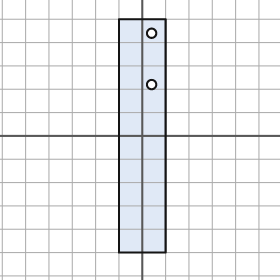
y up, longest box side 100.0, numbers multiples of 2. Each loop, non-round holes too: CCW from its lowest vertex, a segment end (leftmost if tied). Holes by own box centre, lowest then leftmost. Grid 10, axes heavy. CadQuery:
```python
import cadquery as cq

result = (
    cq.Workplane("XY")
    .moveTo(-10.0, -50.0)
    .lineTo(10.0, -50.0)
    .lineTo(10.0, 50.0)
    .lineTo(-10.0, 50.0)
    .close()
    .moveTo(4.0, 22.0)
    .circle(2.0)
    .moveTo(4.0, 44.0)
    .circle(2.0)
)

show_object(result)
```